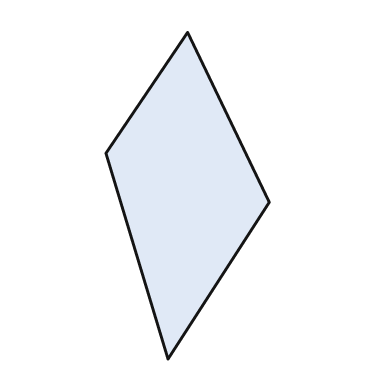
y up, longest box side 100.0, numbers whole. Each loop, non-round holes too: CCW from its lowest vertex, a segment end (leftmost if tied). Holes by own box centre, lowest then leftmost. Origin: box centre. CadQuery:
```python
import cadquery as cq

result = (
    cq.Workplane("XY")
    .moveTo(-6.0, -50.0)
    .lineTo(25.0, -2.0)
    .lineTo(0.0, 50.0)
    .lineTo(-25.0, 13.0)
    .close()
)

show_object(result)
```